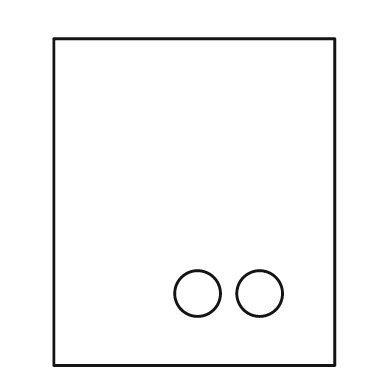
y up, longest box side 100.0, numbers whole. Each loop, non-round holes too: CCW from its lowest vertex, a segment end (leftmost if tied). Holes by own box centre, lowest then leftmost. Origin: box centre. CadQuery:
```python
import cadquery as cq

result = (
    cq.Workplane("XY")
    .moveTo(-43.0, -50.0)
    .lineTo(43.0, -50.0)
    .lineTo(43.0, 50.0)
    .lineTo(-43.0, 50.0)
    .close()
    .moveTo(1.0, -28.0)
    .circle(7.0)
    .moveTo(20.0, -28.0)
    .circle(7.0)
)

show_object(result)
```